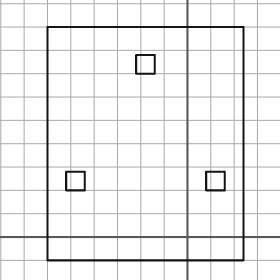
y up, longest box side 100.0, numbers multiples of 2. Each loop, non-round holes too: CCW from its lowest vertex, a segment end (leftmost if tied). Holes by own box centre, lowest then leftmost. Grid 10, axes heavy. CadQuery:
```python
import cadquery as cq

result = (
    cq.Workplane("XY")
    .moveTo(-60.0, -10.0)
    .lineTo(24.0, -10.0)
    .lineTo(24.0, 90.0)
    .lineTo(-60.0, 90.0)
    .close()
    .moveTo(-52.0, 20.0)
    .lineTo(-44.0, 20.0)
    .lineTo(-44.0, 28.0)
    .lineTo(-52.0, 28.0)
    .close()
    .moveTo(8.0, 20.0)
    .lineTo(16.0, 20.0)
    .lineTo(16.0, 28.0)
    .lineTo(8.0, 28.0)
    .close()
    .moveTo(-22.0, 70.0)
    .lineTo(-14.0, 70.0)
    .lineTo(-14.0, 78.0)
    .lineTo(-22.0, 78.0)
    .close()
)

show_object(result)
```